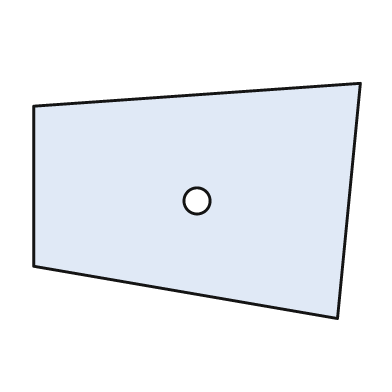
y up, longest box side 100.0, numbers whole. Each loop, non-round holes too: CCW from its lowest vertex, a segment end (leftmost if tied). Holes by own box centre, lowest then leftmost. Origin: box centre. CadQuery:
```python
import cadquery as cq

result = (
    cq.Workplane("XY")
    .moveTo(43.0, -36.0)
    .lineTo(50.0, 36.0)
    .lineTo(-50.0, 29.0)
    .lineTo(-50.0, -20.0)
    .close()
    .moveTo(0.0, 0.0)
    .circle(4.0)
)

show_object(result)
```